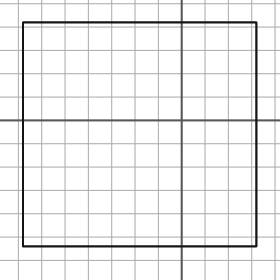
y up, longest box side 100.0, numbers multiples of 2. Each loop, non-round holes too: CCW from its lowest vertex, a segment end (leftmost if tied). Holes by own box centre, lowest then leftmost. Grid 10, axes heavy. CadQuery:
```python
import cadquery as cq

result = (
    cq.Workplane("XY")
    .moveTo(-68.0, -54.0)
    .lineTo(32.0, -54.0)
    .lineTo(32.0, 42.0)
    .lineTo(-68.0, 42.0)
    .close()
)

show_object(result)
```